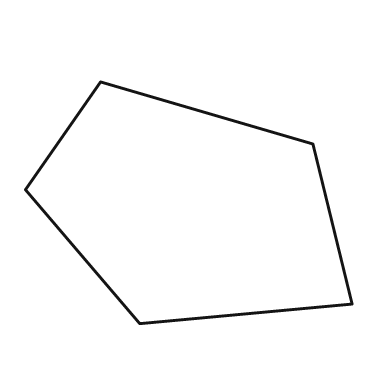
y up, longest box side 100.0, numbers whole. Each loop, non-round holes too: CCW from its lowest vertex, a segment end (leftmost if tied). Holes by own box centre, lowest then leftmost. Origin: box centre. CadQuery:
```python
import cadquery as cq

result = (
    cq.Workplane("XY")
    .moveTo(-15.0, -37.0)
    .lineTo(50.0, -31.0)
    .lineTo(38.0, 18.0)
    .lineTo(-27.0, 37.0)
    .lineTo(-50.0, 4.0)
    .close()
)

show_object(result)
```